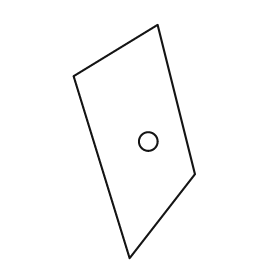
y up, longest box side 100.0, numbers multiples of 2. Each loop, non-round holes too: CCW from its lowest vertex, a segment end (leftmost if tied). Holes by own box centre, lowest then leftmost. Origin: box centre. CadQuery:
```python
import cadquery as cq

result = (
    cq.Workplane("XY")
    .moveTo(-2.0, -50.0)
    .lineTo(26.0, -14.0)
    .lineTo(10.0, 50.0)
    .lineTo(-26.0, 28.0)
    .close()
    .moveTo(6.0, 0.0)
    .circle(4.0)
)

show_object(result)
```